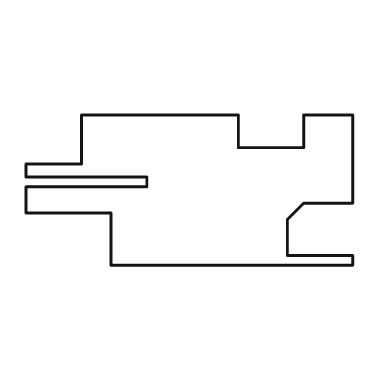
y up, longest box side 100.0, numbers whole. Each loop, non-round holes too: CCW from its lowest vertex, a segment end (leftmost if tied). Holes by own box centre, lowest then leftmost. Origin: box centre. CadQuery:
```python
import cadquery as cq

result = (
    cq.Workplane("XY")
    .moveTo(-24.0, -23.0)
    .lineTo(50.0, -23.0)
    .lineTo(50.0, -20.0)
    .lineTo(30.0, -20.0)
    .lineTo(30.0, -9.0)
    .lineTo(35.0, -4.0)
    .lineTo(50.0, -4.0)
    .lineTo(50.0, 23.0)
    .lineTo(35.0, 23.0)
    .lineTo(35.0, 13.0)
    .lineTo(15.0, 13.0)
    .lineTo(15.0, 23.0)
    .lineTo(-33.0, 23.0)
    .lineTo(-33.0, 8.0)
    .lineTo(-50.0, 8.0)
    .lineTo(-50.0, 4.0)
    .lineTo(-13.0, 4.0)
    .lineTo(-13.0, 1.0)
    .lineTo(-50.0, 1.0)
    .lineTo(-50.0, -7.0)
    .lineTo(-24.0, -7.0)
    .close()
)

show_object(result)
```